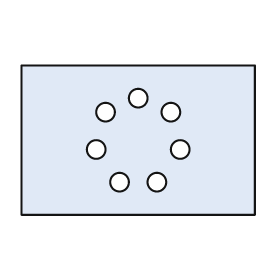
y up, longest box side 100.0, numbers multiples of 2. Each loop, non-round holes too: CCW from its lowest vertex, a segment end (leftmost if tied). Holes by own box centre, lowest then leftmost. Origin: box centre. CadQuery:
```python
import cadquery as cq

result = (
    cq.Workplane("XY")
    .moveTo(-50.0, -32.0)
    .lineTo(50.0, -32.0)
    .lineTo(50.0, 32.0)
    .lineTo(-50.0, 32.0)
    .close()
    .moveTo(-8.0, -18.0)
    .circle(4.0)
    .moveTo(8.0, -18.0)
    .circle(4.0)
    .moveTo(-18.0, -4.0)
    .circle(4.0)
    .moveTo(18.0, -4.0)
    .circle(4.0)
    .moveTo(-14.0, 12.0)
    .circle(4.0)
    .moveTo(14.0, 12.0)
    .circle(4.0)
    .moveTo(0.0, 18.0)
    .circle(4.0)
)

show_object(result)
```